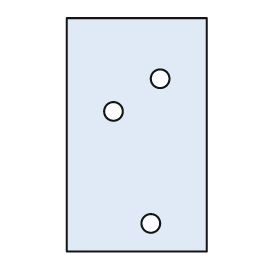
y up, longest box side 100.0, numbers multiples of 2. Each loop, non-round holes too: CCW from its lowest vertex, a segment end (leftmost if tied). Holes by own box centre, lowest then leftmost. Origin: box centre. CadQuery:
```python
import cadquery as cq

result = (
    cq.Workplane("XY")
    .moveTo(-30.0, -50.0)
    .lineTo(30.0, -50.0)
    .lineTo(30.0, 50.0)
    .lineTo(-30.0, 50.0)
    .close()
    .moveTo(6.0, -38.0)
    .circle(4.0)
    .moveTo(-10.0, 10.0)
    .circle(4.0)
    .moveTo(10.0, 24.0)
    .circle(4.0)
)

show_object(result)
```